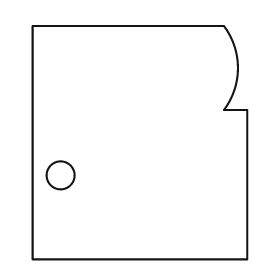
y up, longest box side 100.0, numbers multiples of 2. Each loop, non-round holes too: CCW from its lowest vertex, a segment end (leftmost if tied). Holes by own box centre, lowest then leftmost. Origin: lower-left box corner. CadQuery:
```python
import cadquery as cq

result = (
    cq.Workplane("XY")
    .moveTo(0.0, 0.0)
    .lineTo(92.0, 0.0)
    .lineTo(92.0, 64.0)
    .lineTo(82.0, 64.0)
    .threePointArc((88.0, 82.0), (82.0, 100.0))
    .lineTo(0.0, 100.0)
    .close()
    .moveTo(12.0, 36.0)
    .circle(6.0)
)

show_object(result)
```